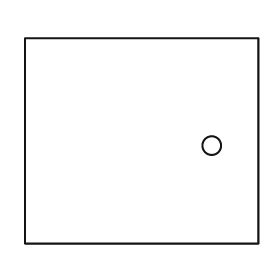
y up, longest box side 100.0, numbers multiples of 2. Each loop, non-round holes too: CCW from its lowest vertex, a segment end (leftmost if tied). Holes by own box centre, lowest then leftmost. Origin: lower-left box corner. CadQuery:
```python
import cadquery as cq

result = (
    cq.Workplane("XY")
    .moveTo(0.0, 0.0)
    .lineTo(100.0, 0.0)
    .lineTo(100.0, 88.0)
    .lineTo(0.0, 88.0)
    .close()
    .moveTo(80.0, 42.0)
    .circle(4.0)
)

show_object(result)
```